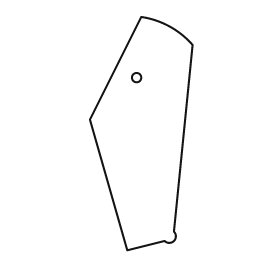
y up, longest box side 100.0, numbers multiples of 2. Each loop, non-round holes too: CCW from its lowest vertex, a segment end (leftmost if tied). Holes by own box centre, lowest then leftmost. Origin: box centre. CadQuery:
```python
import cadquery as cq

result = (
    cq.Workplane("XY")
    .moveTo(-6.0, -50.0)
    .lineTo(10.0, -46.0)
    .threePointArc((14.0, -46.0), (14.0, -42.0))
    .lineTo(22.0, 38.0)
    .threePointArc((12.0, 46.0), (0.0, 50.0))
    .lineTo(-22.0, 6.0)
    .close()
    .moveTo(-2.0, 24.0)
    .circle(2.0)
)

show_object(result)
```